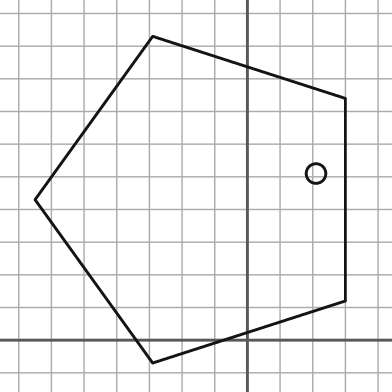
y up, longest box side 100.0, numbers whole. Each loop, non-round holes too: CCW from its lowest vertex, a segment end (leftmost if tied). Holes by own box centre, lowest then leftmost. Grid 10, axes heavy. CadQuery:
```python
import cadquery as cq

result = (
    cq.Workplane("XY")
    .moveTo(-29.0, -7.0)
    .lineTo(30.0, 12.0)
    .lineTo(30.0, 74.0)
    .lineTo(-29.0, 93.0)
    .lineTo(-65.0, 43.0)
    .close()
    .moveTo(21.0, 51.0)
    .circle(3.0)
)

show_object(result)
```